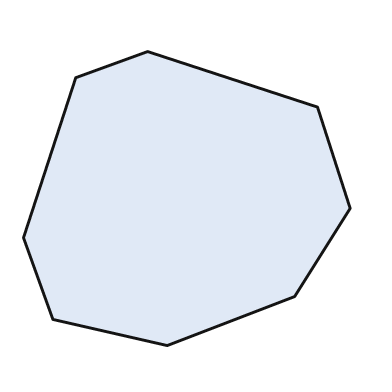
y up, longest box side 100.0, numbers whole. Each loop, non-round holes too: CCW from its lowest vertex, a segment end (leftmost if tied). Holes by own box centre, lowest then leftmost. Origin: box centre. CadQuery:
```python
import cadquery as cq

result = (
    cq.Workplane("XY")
    .moveTo(-6.0, -45.0)
    .lineTo(33.0, -30.0)
    .lineTo(50.0, -3.0)
    .lineTo(40.0, 28.0)
    .lineTo(-12.0, 45.0)
    .lineTo(-34.0, 37.0)
    .lineTo(-50.0, -12.0)
    .lineTo(-41.0, -37.0)
    .close()
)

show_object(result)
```